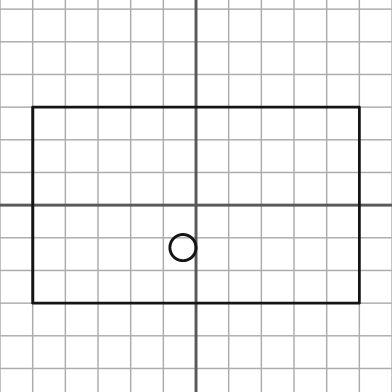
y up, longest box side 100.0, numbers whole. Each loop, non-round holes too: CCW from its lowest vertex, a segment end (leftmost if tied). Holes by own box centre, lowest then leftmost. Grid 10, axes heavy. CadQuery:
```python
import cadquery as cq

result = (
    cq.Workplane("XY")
    .moveTo(-50.0, -30.0)
    .lineTo(50.0, -30.0)
    .lineTo(50.0, 30.0)
    .lineTo(-50.0, 30.0)
    .close()
    .moveTo(-4.0, -13.0)
    .circle(4.0)
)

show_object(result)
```